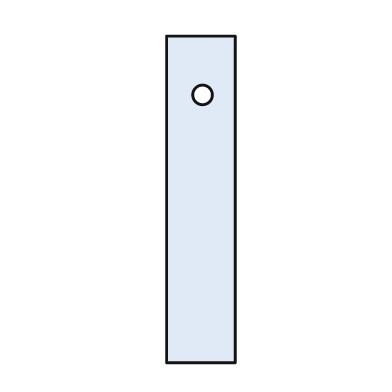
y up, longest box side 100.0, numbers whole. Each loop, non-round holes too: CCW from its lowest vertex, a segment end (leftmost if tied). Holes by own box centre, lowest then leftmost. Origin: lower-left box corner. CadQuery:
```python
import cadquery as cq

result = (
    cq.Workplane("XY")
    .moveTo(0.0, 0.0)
    .lineTo(21.0, 0.0)
    .lineTo(21.0, 100.0)
    .lineTo(0.0, 100.0)
    .close()
    .moveTo(11.0, 82.0)
    .circle(3.0)
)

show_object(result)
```